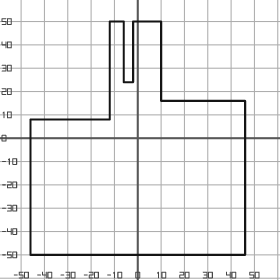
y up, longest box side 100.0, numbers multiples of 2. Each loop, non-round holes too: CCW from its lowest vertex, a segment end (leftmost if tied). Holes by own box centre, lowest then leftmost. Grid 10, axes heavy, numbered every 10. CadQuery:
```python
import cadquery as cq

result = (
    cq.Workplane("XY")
    .moveTo(-46.0, -50.0)
    .lineTo(46.0, -50.0)
    .lineTo(46.0, 16.0)
    .lineTo(10.0, 16.0)
    .lineTo(10.0, 50.0)
    .lineTo(-2.0, 50.0)
    .lineTo(-2.0, 24.0)
    .lineTo(-6.0, 24.0)
    .lineTo(-6.0, 50.0)
    .lineTo(-12.0, 50.0)
    .lineTo(-12.0, 8.0)
    .lineTo(-46.0, 8.0)
    .close()
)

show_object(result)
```